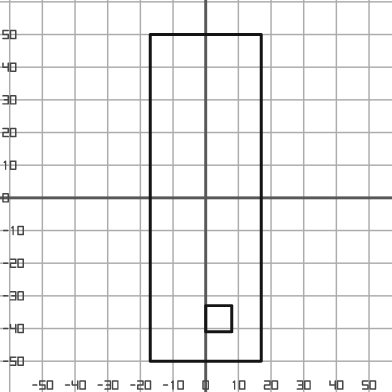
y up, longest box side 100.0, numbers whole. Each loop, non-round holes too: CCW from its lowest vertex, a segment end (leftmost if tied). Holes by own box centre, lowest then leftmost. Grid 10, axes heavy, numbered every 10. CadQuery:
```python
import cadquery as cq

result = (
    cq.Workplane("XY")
    .moveTo(-17.0, -50.0)
    .lineTo(17.0, -50.0)
    .lineTo(17.0, 50.0)
    .lineTo(-17.0, 50.0)
    .close()
    .moveTo(0.0, -41.0)
    .lineTo(8.0, -41.0)
    .lineTo(8.0, -33.0)
    .lineTo(0.0, -33.0)
    .close()
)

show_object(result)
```